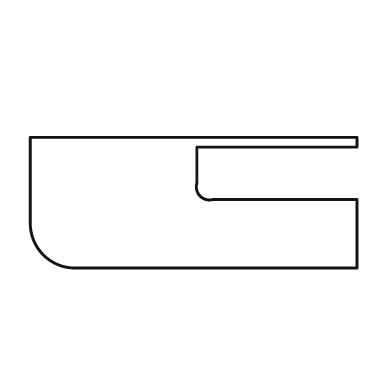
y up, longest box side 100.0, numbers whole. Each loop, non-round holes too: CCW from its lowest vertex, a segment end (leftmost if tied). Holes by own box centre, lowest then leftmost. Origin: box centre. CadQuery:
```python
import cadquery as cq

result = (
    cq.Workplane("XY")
    .moveTo(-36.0, -20.0)
    .lineTo(50.0, -20.0)
    .lineTo(50.0, 1.0)
    .lineTo(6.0, 1.0)
    .threePointArc((2.0, 2.0), (1.0, 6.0))
    .lineTo(1.0, 17.0)
    .lineTo(50.0, 17.0)
    .lineTo(50.0, 20.0)
    .lineTo(-50.0, 20.0)
    .lineTo(-50.0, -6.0)
    .threePointArc((-46.0, -16.0), (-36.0, -20.0))
    .close()
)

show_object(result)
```